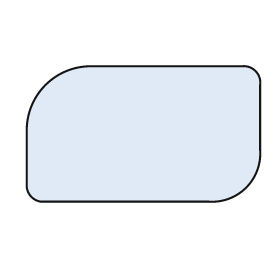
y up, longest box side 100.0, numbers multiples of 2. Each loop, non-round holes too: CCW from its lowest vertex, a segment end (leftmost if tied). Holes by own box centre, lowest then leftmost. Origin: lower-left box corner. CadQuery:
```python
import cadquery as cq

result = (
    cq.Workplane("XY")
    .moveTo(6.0, 0.0)
    .lineTo(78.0, 0.0)
    .threePointArc((94.0, 6.0), (100.0, 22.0))
    .lineTo(100.0, 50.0)
    .threePointArc((98.0, 56.0), (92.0, 58.0))
    .lineTo(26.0, 58.0)
    .threePointArc((8.0, 50.0), (0.0, 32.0))
    .lineTo(0.0, 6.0)
    .threePointArc((2.0, 2.0), (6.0, 0.0))
    .close()
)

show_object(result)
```